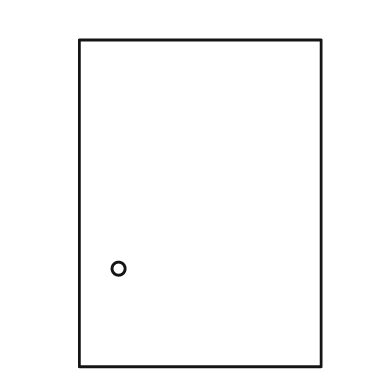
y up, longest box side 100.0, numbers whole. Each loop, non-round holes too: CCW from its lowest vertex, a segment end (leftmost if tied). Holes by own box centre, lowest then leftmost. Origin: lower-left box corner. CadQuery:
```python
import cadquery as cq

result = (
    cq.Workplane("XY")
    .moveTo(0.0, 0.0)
    .lineTo(74.0, 0.0)
    .lineTo(74.0, 100.0)
    .lineTo(0.0, 100.0)
    .close()
    .moveTo(12.0, 30.0)
    .circle(2.0)
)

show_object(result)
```